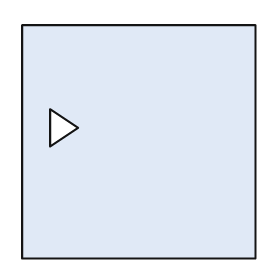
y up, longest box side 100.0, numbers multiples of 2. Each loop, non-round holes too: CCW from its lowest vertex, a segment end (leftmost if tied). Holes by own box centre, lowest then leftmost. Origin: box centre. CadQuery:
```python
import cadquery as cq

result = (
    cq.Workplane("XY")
    .moveTo(-50.0, -50.0)
    .lineTo(50.0, -50.0)
    .lineTo(50.0, 50.0)
    .lineTo(-50.0, 50.0)
    .close()
    .moveTo(-38.0, -2.0)
    .lineTo(-26.0, 6.0)
    .lineTo(-38.0, 14.0)
    .close()
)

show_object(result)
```